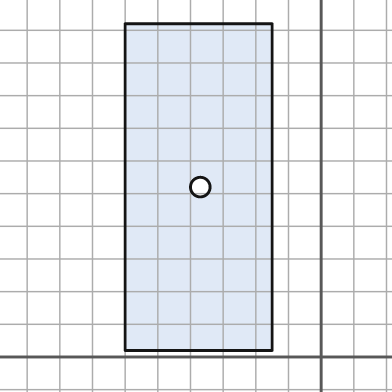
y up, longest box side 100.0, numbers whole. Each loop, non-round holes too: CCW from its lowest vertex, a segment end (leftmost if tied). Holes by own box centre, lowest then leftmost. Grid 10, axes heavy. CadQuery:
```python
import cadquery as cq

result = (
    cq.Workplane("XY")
    .moveTo(-60.0, 2.0)
    .lineTo(-15.0, 2.0)
    .lineTo(-15.0, 102.0)
    .lineTo(-60.0, 102.0)
    .close()
    .moveTo(-37.0, 52.0)
    .circle(3.0)
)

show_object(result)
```